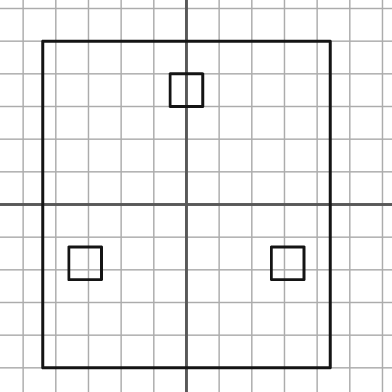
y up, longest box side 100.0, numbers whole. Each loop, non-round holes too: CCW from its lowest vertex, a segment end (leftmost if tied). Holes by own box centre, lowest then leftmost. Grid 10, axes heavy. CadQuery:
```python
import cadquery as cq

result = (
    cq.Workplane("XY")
    .moveTo(-44.0, -50.0)
    .lineTo(44.0, -50.0)
    .lineTo(44.0, 50.0)
    .lineTo(-44.0, 50.0)
    .close()
    .moveTo(-36.0, -23.0)
    .lineTo(-26.0, -23.0)
    .lineTo(-26.0, -13.0)
    .lineTo(-36.0, -13.0)
    .close()
    .moveTo(26.0, -23.0)
    .lineTo(36.0, -23.0)
    .lineTo(36.0, -13.0)
    .lineTo(26.0, -13.0)
    .close()
    .moveTo(-5.0, 30.0)
    .lineTo(5.0, 30.0)
    .lineTo(5.0, 40.0)
    .lineTo(-5.0, 40.0)
    .close()
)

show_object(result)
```